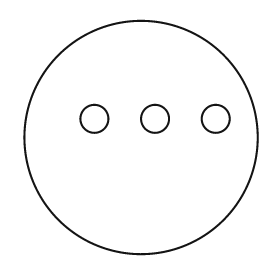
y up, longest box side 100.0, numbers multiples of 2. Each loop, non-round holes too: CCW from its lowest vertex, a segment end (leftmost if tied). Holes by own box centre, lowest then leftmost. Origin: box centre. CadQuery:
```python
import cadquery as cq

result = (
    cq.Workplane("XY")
    .moveTo(0.0, 0.0)
    .circle(50.0)
    .moveTo(-20.0, 8.0)
    .circle(6.0)
    .moveTo(6.0, 8.0)
    .circle(6.0)
    .moveTo(32.0, 8.0)
    .circle(6.0)
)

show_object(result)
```